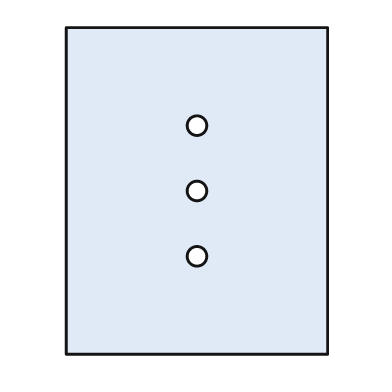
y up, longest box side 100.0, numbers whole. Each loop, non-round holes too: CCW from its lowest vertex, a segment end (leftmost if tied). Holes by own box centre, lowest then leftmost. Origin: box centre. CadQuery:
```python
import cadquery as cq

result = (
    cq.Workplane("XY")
    .moveTo(-40.0, -50.0)
    .lineTo(40.0, -50.0)
    .lineTo(40.0, 50.0)
    .lineTo(-40.0, 50.0)
    .close()
    .moveTo(0.0, -20.0)
    .circle(3.0)
    .moveTo(0.0, 0.0)
    .circle(3.0)
    .moveTo(0.0, 20.0)
    .circle(3.0)
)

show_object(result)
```